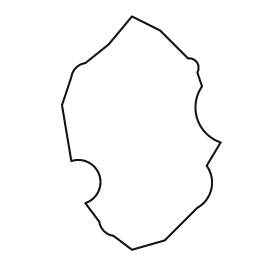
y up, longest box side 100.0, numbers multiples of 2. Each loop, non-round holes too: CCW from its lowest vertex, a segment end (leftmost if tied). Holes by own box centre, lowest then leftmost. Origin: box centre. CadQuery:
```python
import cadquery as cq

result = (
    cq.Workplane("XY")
    .moveTo(-4.0, -50.0)
    .lineTo(10.0, -46.0)
    .lineTo(24.0, -32.0)
    .threePointArc((30.0, -24.0), (28.0, -14.0))
    .lineTo(34.0, -4.0)
    .threePointArc((24.0, 6.0), (26.0, 20.0))
    .lineTo(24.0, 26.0)
    .threePointArc((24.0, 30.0), (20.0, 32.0))
    .lineTo(8.0, 44.0)
    .lineTo(-4.0, 50.0)
    .lineTo(-14.0, 38.0)
    .lineTo(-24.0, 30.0)
    .threePointArc((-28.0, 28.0), (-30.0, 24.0))
    .lineTo(-34.0, 12.0)
    .lineTo(-30.0, -12.0)
    .threePointArc((-18.0, -18.0), (-24.0, -30.0))
    .lineTo(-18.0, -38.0)
    .threePointArc((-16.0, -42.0), (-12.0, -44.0))
    .close()
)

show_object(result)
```